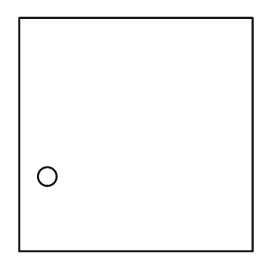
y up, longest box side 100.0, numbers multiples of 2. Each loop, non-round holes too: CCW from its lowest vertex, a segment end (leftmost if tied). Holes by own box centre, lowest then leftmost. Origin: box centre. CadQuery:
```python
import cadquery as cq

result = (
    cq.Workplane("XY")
    .moveTo(-50.0, -50.0)
    .lineTo(50.0, -50.0)
    .lineTo(50.0, 50.0)
    .lineTo(-50.0, 50.0)
    .close()
    .moveTo(-38.0, -18.0)
    .circle(4.0)
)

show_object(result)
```